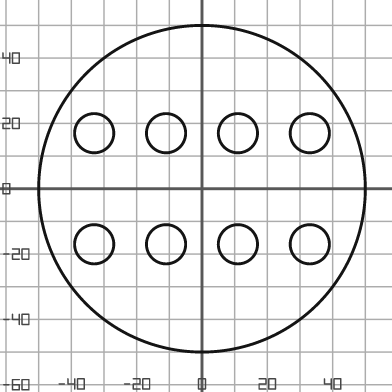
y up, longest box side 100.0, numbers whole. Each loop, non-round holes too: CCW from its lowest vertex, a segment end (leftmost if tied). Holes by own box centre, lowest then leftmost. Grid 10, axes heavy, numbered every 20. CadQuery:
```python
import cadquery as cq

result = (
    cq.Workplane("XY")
    .moveTo(0.0, 0.0)
    .circle(50.0)
    .moveTo(-33.0, -17.0)
    .circle(6.0)
    .moveTo(-11.0, -17.0)
    .circle(6.0)
    .moveTo(11.0, -17.0)
    .circle(6.0)
    .moveTo(33.0, -17.0)
    .circle(6.0)
    .moveTo(-33.0, 17.0)
    .circle(6.0)
    .moveTo(-11.0, 17.0)
    .circle(6.0)
    .moveTo(11.0, 17.0)
    .circle(6.0)
    .moveTo(33.0, 17.0)
    .circle(6.0)
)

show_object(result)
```